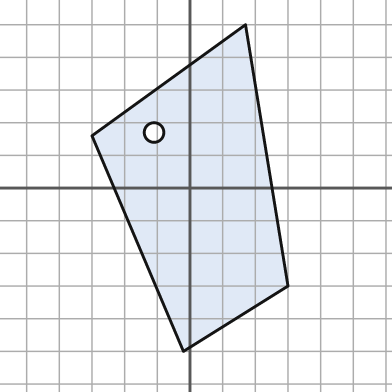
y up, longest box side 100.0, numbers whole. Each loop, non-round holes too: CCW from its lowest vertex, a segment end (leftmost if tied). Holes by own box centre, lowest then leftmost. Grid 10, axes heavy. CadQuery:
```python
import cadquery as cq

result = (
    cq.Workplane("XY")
    .moveTo(-2.0, -50.0)
    .lineTo(30.0, -30.0)
    .lineTo(17.0, 50.0)
    .lineTo(-30.0, 16.0)
    .close()
    .moveTo(-11.0, 17.0)
    .circle(3.0)
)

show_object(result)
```